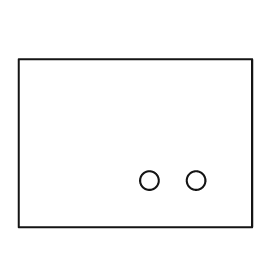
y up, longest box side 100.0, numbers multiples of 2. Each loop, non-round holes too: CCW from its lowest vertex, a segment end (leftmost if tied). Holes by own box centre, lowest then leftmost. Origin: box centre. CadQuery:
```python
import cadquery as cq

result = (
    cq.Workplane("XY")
    .moveTo(-50.0, -36.0)
    .lineTo(50.0, -36.0)
    .lineTo(50.0, 36.0)
    .lineTo(-50.0, 36.0)
    .close()
    .moveTo(6.0, -16.0)
    .circle(4.0)
    .moveTo(26.0, -16.0)
    .circle(4.0)
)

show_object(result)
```